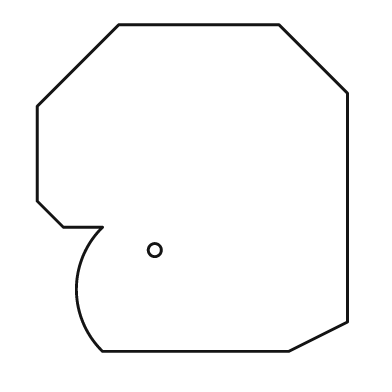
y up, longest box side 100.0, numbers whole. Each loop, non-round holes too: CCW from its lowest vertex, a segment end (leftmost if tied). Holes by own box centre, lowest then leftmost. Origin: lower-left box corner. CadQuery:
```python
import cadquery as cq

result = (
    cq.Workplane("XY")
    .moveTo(20.0, 0.0)
    .lineTo(77.0, 0.0)
    .lineTo(95.0, 9.0)
    .lineTo(95.0, 79.0)
    .lineTo(74.0, 100.0)
    .lineTo(25.0, 100.0)
    .lineTo(0.0, 75.0)
    .lineTo(0.0, 46.0)
    .lineTo(8.0, 38.0)
    .lineTo(20.0, 38.0)
    .threePointArc((12.0, 19.0), (20.0, 0.0))
    .close()
    .moveTo(36.0, 31.0)
    .circle(2.0)
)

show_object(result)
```